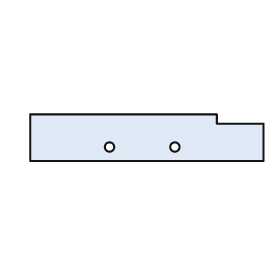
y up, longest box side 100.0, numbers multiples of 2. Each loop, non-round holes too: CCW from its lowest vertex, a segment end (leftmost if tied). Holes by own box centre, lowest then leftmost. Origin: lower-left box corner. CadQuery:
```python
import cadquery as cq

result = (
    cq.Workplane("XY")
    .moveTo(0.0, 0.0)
    .lineTo(100.0, 0.0)
    .lineTo(100.0, 16.0)
    .lineTo(80.0, 16.0)
    .lineTo(80.0, 20.0)
    .lineTo(0.0, 20.0)
    .close()
    .moveTo(34.0, 6.0)
    .circle(2.0)
    .moveTo(62.0, 6.0)
    .circle(2.0)
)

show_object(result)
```